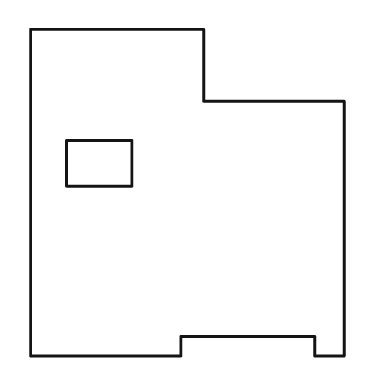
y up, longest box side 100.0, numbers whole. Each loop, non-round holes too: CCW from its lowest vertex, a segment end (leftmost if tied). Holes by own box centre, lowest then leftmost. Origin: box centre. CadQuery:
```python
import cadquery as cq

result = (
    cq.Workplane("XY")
    .moveTo(-48.0, -50.0)
    .lineTo(-2.0, -50.0)
    .lineTo(-2.0, -44.0)
    .lineTo(39.0, -44.0)
    .lineTo(39.0, -50.0)
    .lineTo(48.0, -50.0)
    .lineTo(48.0, 28.0)
    .lineTo(5.0, 28.0)
    .lineTo(5.0, 50.0)
    .lineTo(-48.0, 50.0)
    .close()
    .moveTo(-37.0, 2.0)
    .lineTo(-17.0, 2.0)
    .lineTo(-17.0, 16.0)
    .lineTo(-37.0, 16.0)
    .close()
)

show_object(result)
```